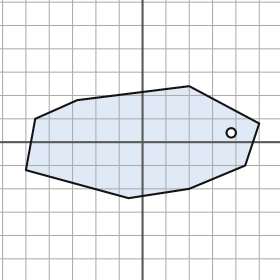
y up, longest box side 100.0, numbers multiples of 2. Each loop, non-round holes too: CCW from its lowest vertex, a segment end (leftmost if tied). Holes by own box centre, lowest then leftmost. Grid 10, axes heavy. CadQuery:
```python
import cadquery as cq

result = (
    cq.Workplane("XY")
    .moveTo(-6.0, -24.0)
    .lineTo(20.0, -20.0)
    .lineTo(44.0, -10.0)
    .lineTo(50.0, 8.0)
    .lineTo(20.0, 24.0)
    .lineTo(-28.0, 18.0)
    .lineTo(-46.0, 10.0)
    .lineTo(-50.0, -12.0)
    .close()
    .moveTo(38.0, 4.0)
    .circle(2.0)
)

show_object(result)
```